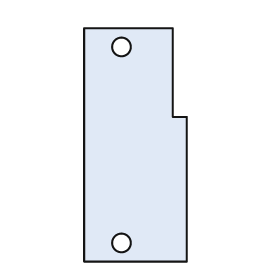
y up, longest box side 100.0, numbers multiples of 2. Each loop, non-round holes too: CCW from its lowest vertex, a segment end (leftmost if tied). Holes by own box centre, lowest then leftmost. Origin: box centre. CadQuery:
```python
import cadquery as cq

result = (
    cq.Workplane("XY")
    .moveTo(-22.0, -50.0)
    .lineTo(22.0, -50.0)
    .lineTo(22.0, 12.0)
    .lineTo(16.0, 12.0)
    .lineTo(16.0, 50.0)
    .lineTo(-22.0, 50.0)
    .close()
    .moveTo(-6.0, -42.0)
    .circle(4.0)
    .moveTo(-6.0, 42.0)
    .circle(4.0)
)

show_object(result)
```